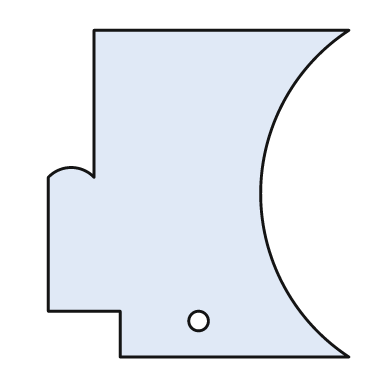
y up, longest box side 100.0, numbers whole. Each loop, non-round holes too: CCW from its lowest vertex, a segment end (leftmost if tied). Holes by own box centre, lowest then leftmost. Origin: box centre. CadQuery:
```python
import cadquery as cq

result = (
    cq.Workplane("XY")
    .moveTo(-24.0, -50.0)
    .lineTo(46.0, -50.0)
    .threePointArc((19.0, 0.0), (46.0, 50.0))
    .lineTo(-32.0, 50.0)
    .lineTo(-32.0, 5.0)
    .threePointArc((-39.0, 8.0), (-46.0, 5.0))
    .lineTo(-46.0, -36.0)
    .lineTo(-24.0, -36.0)
    .close()
    .moveTo(0.0, -39.0)
    .circle(3.0)
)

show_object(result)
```